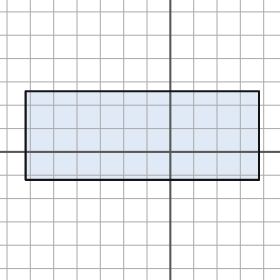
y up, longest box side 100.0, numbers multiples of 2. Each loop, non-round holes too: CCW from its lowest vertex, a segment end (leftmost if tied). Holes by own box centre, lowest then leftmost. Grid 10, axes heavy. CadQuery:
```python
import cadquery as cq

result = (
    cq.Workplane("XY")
    .moveTo(-62.0, -12.0)
    .lineTo(38.0, -12.0)
    .lineTo(38.0, 26.0)
    .lineTo(-62.0, 26.0)
    .close()
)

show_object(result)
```